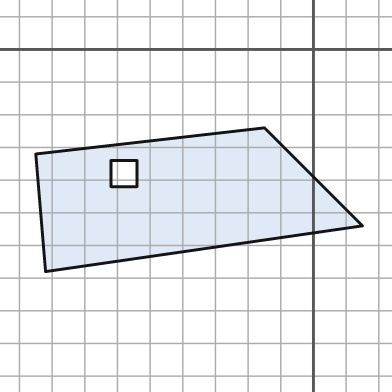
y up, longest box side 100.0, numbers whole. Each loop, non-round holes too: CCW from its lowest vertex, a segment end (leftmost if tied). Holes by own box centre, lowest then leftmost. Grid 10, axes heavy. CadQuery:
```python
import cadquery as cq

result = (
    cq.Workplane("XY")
    .moveTo(-82.0, -68.0)
    .lineTo(15.0, -54.0)
    .lineTo(-15.0, -24.0)
    .lineTo(-85.0, -32.0)
    .close()
    .moveTo(-62.0, -42.0)
    .lineTo(-54.0, -42.0)
    .lineTo(-54.0, -34.0)
    .lineTo(-62.0, -34.0)
    .close()
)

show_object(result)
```